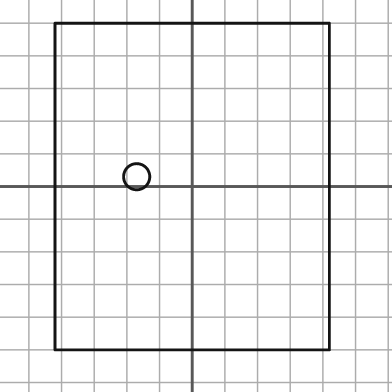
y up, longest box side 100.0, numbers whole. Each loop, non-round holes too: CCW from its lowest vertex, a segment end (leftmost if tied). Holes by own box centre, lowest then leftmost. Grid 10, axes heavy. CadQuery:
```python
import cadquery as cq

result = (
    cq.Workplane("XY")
    .moveTo(-42.0, -50.0)
    .lineTo(42.0, -50.0)
    .lineTo(42.0, 50.0)
    .lineTo(-42.0, 50.0)
    .close()
    .moveTo(-17.0, 3.0)
    .circle(4.0)
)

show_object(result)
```